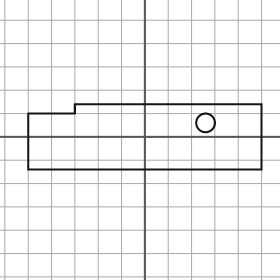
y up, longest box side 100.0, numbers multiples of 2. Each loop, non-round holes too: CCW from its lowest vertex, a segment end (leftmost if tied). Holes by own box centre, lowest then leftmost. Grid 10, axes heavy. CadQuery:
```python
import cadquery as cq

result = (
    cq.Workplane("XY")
    .moveTo(-50.0, -14.0)
    .lineTo(50.0, -14.0)
    .lineTo(50.0, 14.0)
    .lineTo(-30.0, 14.0)
    .lineTo(-30.0, 10.0)
    .lineTo(-50.0, 10.0)
    .close()
    .moveTo(26.0, 6.0)
    .circle(4.0)
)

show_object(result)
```